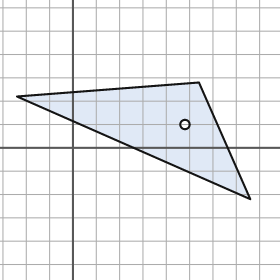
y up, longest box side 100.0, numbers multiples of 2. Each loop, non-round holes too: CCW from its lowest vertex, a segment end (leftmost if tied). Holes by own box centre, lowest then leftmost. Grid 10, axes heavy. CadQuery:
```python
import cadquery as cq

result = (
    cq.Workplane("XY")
    .moveTo(76.0, -22.0)
    .lineTo(54.0, 28.0)
    .lineTo(-24.0, 22.0)
    .close()
    .moveTo(48.0, 10.0)
    .circle(2.0)
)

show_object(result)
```